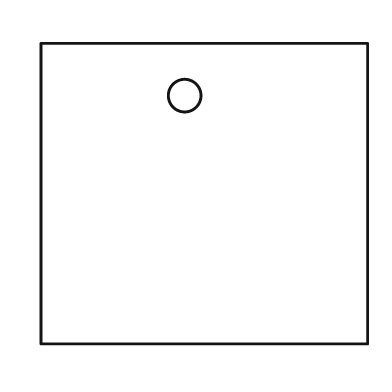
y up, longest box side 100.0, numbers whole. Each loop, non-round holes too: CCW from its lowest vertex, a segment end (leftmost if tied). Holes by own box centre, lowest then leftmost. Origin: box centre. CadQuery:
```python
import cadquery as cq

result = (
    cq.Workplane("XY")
    .moveTo(-50.0, -46.0)
    .lineTo(50.0, -46.0)
    .lineTo(50.0, 46.0)
    .lineTo(-50.0, 46.0)
    .close()
    .moveTo(-6.0, 30.0)
    .circle(5.0)
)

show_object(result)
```